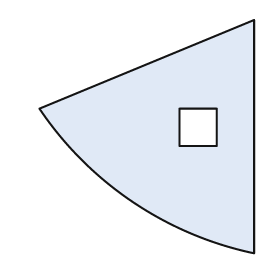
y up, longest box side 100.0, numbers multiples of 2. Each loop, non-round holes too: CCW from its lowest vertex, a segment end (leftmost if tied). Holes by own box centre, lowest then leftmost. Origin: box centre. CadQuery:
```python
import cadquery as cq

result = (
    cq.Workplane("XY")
    .moveTo(46.0, -50.0)
    .lineTo(46.0, 50.0)
    .lineTo(-46.0, 12.0)
    .threePointArc((-6.0, -28.0), (46.0, -50.0))
    .close()
    .moveTo(14.0, -4.0)
    .lineTo(30.0, -4.0)
    .lineTo(30.0, 12.0)
    .lineTo(14.0, 12.0)
    .close()
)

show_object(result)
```